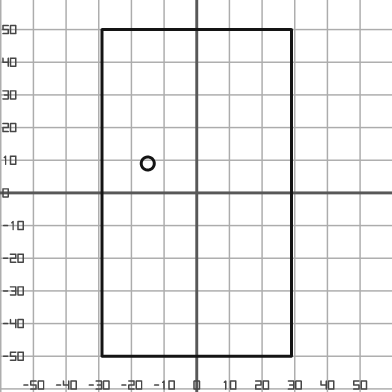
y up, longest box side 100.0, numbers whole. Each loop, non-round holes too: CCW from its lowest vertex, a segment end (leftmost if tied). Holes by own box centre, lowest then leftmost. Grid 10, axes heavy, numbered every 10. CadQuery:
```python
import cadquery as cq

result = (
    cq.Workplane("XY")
    .moveTo(-29.0, -50.0)
    .lineTo(29.0, -50.0)
    .lineTo(29.0, 50.0)
    .lineTo(-29.0, 50.0)
    .close()
    .moveTo(-15.0, 9.0)
    .circle(2.0)
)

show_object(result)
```